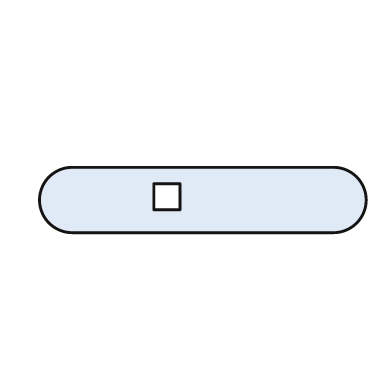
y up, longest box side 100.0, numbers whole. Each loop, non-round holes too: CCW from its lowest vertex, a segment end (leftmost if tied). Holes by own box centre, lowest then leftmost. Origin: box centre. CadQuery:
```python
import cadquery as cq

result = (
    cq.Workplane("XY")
    .moveTo(-40.0, -10.0)
    .lineTo(40.0, -10.0)
    .threePointArc((50.0, 0.0), (40.0, 10.0))
    .lineTo(-40.0, 10.0)
    .threePointArc((-50.0, 0.0), (-40.0, -10.0))
    .close()
    .moveTo(-15.0, -3.0)
    .lineTo(-7.0, -3.0)
    .lineTo(-7.0, 5.0)
    .lineTo(-15.0, 5.0)
    .close()
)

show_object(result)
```